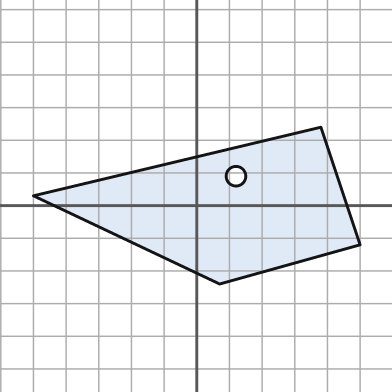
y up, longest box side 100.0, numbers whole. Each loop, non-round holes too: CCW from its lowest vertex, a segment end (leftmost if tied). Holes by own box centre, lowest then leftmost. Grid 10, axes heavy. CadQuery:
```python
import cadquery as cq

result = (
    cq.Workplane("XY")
    .moveTo(7.0, -24.0)
    .lineTo(50.0, -12.0)
    .lineTo(38.0, 24.0)
    .lineTo(-50.0, 3.0)
    .close()
    .moveTo(12.0, 9.0)
    .circle(3.0)
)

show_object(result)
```